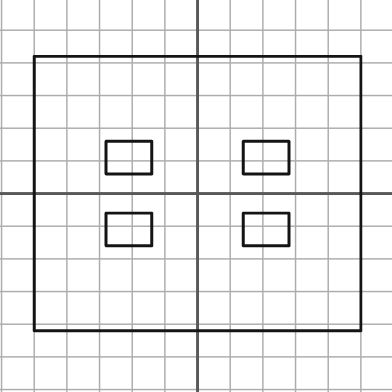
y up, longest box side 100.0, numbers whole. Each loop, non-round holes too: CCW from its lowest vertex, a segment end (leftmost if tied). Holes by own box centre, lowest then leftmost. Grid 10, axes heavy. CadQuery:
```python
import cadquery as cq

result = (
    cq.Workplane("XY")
    .moveTo(-50.0, -42.0)
    .lineTo(50.0, -42.0)
    .lineTo(50.0, 42.0)
    .lineTo(-50.0, 42.0)
    .close()
    .moveTo(-28.0, -16.0)
    .lineTo(-14.0, -16.0)
    .lineTo(-14.0, -6.0)
    .lineTo(-28.0, -6.0)
    .close()
    .moveTo(14.0, -16.0)
    .lineTo(28.0, -16.0)
    .lineTo(28.0, -6.0)
    .lineTo(14.0, -6.0)
    .close()
    .moveTo(-28.0, 6.0)
    .lineTo(-14.0, 6.0)
    .lineTo(-14.0, 16.0)
    .lineTo(-28.0, 16.0)
    .close()
    .moveTo(14.0, 6.0)
    .lineTo(28.0, 6.0)
    .lineTo(28.0, 16.0)
    .lineTo(14.0, 16.0)
    .close()
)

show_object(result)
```